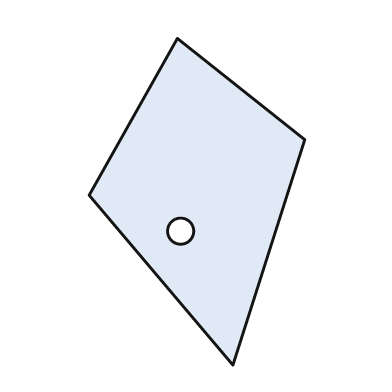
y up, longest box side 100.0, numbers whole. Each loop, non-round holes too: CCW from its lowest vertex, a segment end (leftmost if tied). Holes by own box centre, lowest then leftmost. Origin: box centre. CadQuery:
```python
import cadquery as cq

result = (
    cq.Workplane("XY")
    .moveTo(11.0, -50.0)
    .lineTo(33.0, 19.0)
    .lineTo(-6.0, 50.0)
    .lineTo(-33.0, 2.0)
    .close()
    .moveTo(-5.0, -9.0)
    .circle(4.0)
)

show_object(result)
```